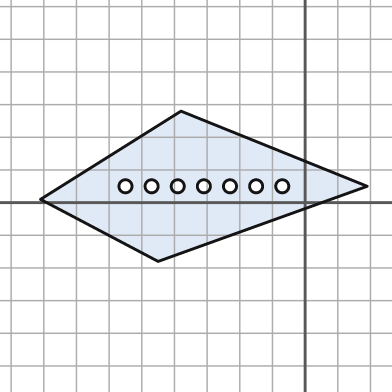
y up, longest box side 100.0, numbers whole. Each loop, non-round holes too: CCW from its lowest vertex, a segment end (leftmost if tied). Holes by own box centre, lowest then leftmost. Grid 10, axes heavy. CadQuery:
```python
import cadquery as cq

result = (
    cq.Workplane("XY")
    .moveTo(-45.0, -18.0)
    .lineTo(19.0, 5.0)
    .lineTo(-38.0, 28.0)
    .lineTo(-81.0, 1.0)
    .close()
    .moveTo(-55.0, 5.0)
    .circle(2.0)
    .moveTo(-47.0, 5.0)
    .circle(2.0)
    .moveTo(-39.0, 5.0)
    .circle(2.0)
    .moveTo(-31.0, 5.0)
    .circle(2.0)
    .moveTo(-23.0, 5.0)
    .circle(2.0)
    .moveTo(-15.0, 5.0)
    .circle(2.0)
    .moveTo(-7.0, 5.0)
    .circle(2.0)
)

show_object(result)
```